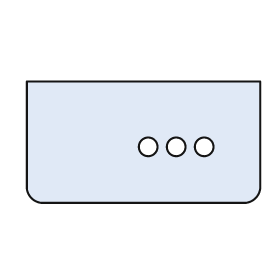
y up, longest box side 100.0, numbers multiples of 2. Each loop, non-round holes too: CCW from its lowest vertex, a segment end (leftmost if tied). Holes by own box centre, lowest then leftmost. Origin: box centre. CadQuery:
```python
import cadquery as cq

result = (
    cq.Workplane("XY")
    .moveTo(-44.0, -26.0)
    .lineTo(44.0, -26.0)
    .threePointArc((48.0, -24.0), (50.0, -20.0))
    .lineTo(50.0, 26.0)
    .lineTo(-50.0, 26.0)
    .lineTo(-50.0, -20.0)
    .threePointArc((-48.0, -24.0), (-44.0, -26.0))
    .close()
    .moveTo(2.0, -2.0)
    .circle(4.0)
    .moveTo(14.0, -2.0)
    .circle(4.0)
    .moveTo(26.0, -2.0)
    .circle(4.0)
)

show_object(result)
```